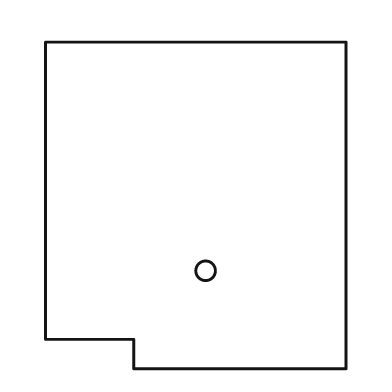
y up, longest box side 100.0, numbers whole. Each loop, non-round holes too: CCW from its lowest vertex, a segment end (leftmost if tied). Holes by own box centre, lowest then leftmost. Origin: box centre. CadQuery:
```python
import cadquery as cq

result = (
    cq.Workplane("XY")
    .moveTo(-19.0, -50.0)
    .lineTo(46.0, -50.0)
    .lineTo(46.0, 50.0)
    .lineTo(-46.0, 50.0)
    .lineTo(-46.0, -41.0)
    .lineTo(-19.0, -41.0)
    .close()
    .moveTo(3.0, -20.0)
    .circle(3.0)
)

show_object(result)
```